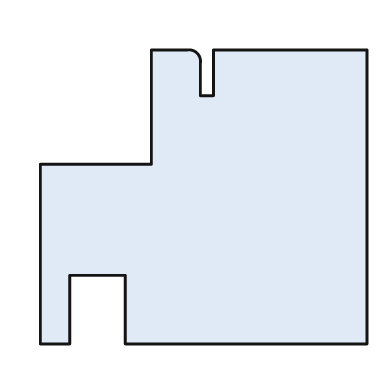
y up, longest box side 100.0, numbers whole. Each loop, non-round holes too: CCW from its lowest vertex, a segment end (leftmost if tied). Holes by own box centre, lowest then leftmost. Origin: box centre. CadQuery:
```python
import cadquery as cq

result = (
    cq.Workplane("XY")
    .moveTo(-50.0, -45.0)
    .lineTo(-41.0, -45.0)
    .lineTo(-41.0, -24.0)
    .lineTo(-24.0, -24.0)
    .lineTo(-24.0, -45.0)
    .lineTo(50.0, -45.0)
    .lineTo(50.0, 45.0)
    .lineTo(3.0, 45.0)
    .lineTo(3.0, 31.0)
    .lineTo(-1.0, 31.0)
    .lineTo(-1.0, 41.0)
    .threePointArc((-2.0, 44.0), (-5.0, 45.0))
    .lineTo(-16.0, 45.0)
    .lineTo(-16.0, 10.0)
    .lineTo(-50.0, 10.0)
    .close()
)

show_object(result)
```